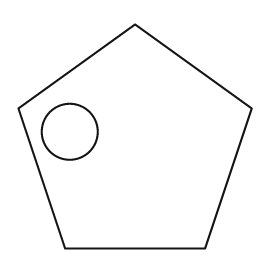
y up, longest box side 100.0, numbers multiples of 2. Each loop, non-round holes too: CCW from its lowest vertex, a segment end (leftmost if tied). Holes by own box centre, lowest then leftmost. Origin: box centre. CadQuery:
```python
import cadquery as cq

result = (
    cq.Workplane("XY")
    .moveTo(-30.0, -48.0)
    .lineTo(30.0, -48.0)
    .lineTo(50.0, 12.0)
    .lineTo(0.0, 48.0)
    .lineTo(-50.0, 12.0)
    .close()
    .moveTo(-28.0, 2.0)
    .circle(12.0)
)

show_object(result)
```